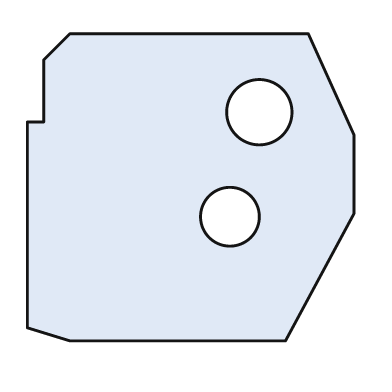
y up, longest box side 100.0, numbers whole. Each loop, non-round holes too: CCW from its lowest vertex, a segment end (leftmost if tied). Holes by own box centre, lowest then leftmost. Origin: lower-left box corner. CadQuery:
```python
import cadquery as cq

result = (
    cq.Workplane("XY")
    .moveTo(13.0, 0.0)
    .lineTo(79.0, 0.0)
    .lineTo(100.0, 39.0)
    .lineTo(100.0, 63.0)
    .lineTo(86.0, 94.0)
    .lineTo(13.0, 94.0)
    .lineTo(5.0, 86.0)
    .lineTo(5.0, 67.0)
    .lineTo(0.0, 67.0)
    .lineTo(0.0, 4.0)
    .close()
    .moveTo(62.0, 38.0)
    .circle(9.0)
    .moveTo(71.0, 70.0)
    .circle(10.0)
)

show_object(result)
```